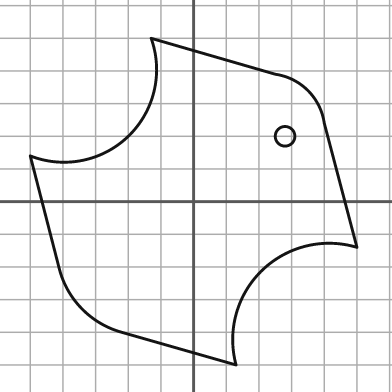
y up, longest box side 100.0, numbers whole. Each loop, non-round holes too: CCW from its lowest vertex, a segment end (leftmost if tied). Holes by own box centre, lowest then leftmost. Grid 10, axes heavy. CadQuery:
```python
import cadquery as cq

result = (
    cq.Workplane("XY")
    .moveTo(13.0, -50.0)
    .threePointArc((21.0, -21.0), (50.0, -14.0))
    .lineTo(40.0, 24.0)
    .threePointArc((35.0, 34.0), (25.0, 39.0))
    .lineTo(-13.0, 50.0)
    .threePointArc((-20.0, 20.0), (-50.0, 14.0))
    .lineTo(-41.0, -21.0)
    .threePointArc((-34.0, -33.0), (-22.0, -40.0))
    .close()
    .moveTo(28.0, 20.0)
    .circle(3.0)
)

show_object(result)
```